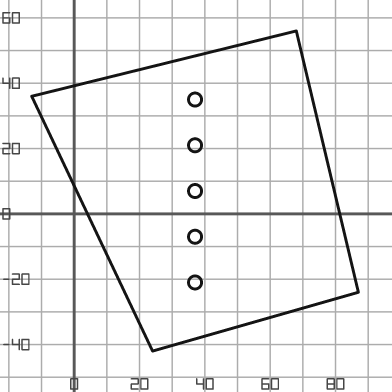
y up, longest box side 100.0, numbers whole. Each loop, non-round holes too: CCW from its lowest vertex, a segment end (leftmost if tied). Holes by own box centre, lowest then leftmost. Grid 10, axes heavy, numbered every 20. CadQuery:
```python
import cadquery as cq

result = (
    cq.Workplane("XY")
    .moveTo(24.0, -42.0)
    .lineTo(87.0, -24.0)
    .lineTo(68.0, 56.0)
    .lineTo(-13.0, 36.0)
    .close()
    .moveTo(37.0, -21.0)
    .circle(2.0)
    .moveTo(37.0, -7.0)
    .circle(2.0)
    .moveTo(37.0, 7.0)
    .circle(2.0)
    .moveTo(37.0, 21.0)
    .circle(2.0)
    .moveTo(37.0, 35.0)
    .circle(2.0)
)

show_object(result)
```